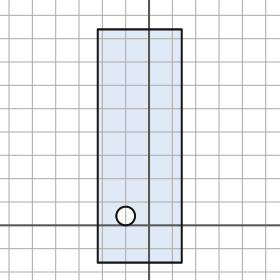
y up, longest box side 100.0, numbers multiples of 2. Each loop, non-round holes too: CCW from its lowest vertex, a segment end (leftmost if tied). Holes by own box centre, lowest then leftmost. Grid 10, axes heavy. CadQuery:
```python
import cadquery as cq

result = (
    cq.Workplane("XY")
    .moveTo(-22.0, -16.0)
    .lineTo(14.0, -16.0)
    .lineTo(14.0, 84.0)
    .lineTo(-22.0, 84.0)
    .close()
    .moveTo(-10.0, 4.0)
    .circle(4.0)
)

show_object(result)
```